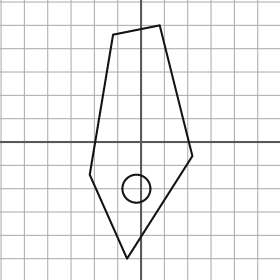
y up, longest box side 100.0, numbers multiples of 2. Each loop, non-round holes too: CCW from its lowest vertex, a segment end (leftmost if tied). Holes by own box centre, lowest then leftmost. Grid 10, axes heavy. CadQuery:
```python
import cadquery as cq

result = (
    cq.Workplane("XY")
    .moveTo(-6.0, -50.0)
    .lineTo(22.0, -6.0)
    .lineTo(8.0, 50.0)
    .lineTo(-12.0, 46.0)
    .lineTo(-22.0, -14.0)
    .close()
    .moveTo(-2.0, -20.0)
    .circle(6.0)
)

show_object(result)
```